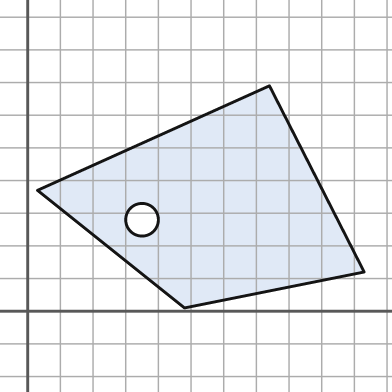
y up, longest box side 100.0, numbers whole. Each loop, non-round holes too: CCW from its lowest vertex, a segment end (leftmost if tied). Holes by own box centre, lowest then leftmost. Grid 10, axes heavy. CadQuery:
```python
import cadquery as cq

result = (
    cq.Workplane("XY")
    .moveTo(48.0, 1.0)
    .lineTo(103.0, 12.0)
    .lineTo(74.0, 69.0)
    .lineTo(3.0, 37.0)
    .close()
    .moveTo(35.0, 28.0)
    .circle(5.0)
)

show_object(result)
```